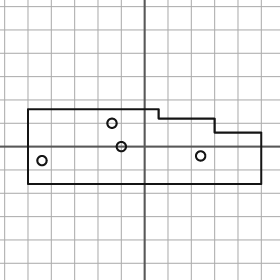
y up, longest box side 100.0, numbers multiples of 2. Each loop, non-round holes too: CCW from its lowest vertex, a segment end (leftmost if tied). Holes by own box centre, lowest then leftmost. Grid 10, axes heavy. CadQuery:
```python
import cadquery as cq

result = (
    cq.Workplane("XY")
    .moveTo(-50.0, -16.0)
    .lineTo(50.0, -16.0)
    .lineTo(50.0, 6.0)
    .lineTo(30.0, 6.0)
    .lineTo(30.0, 12.0)
    .lineTo(6.0, 12.0)
    .lineTo(6.0, 16.0)
    .lineTo(-50.0, 16.0)
    .close()
    .moveTo(-44.0, -6.0)
    .circle(2.0)
    .moveTo(24.0, -4.0)
    .circle(2.0)
    .moveTo(-10.0, 0.0)
    .circle(2.0)
    .moveTo(-14.0, 10.0)
    .circle(2.0)
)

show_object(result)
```